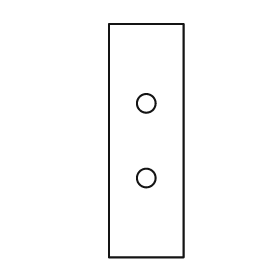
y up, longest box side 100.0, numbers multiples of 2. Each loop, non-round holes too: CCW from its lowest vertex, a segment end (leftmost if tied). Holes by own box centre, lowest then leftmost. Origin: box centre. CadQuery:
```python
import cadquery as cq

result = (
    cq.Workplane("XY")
    .moveTo(-16.0, -50.0)
    .lineTo(16.0, -50.0)
    .lineTo(16.0, 50.0)
    .lineTo(-16.0, 50.0)
    .close()
    .moveTo(0.0, -16.0)
    .circle(4.0)
    .moveTo(0.0, 16.0)
    .circle(4.0)
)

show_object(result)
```